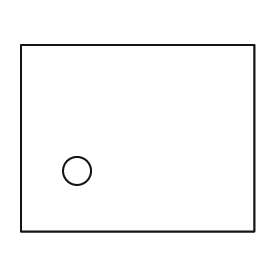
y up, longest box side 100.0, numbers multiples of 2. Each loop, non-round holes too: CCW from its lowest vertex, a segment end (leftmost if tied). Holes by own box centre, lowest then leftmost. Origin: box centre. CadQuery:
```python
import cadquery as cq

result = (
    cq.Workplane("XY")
    .moveTo(-50.0, -40.0)
    .lineTo(50.0, -40.0)
    .lineTo(50.0, 40.0)
    .lineTo(-50.0, 40.0)
    .close()
    .moveTo(-26.0, -14.0)
    .circle(6.0)
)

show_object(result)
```